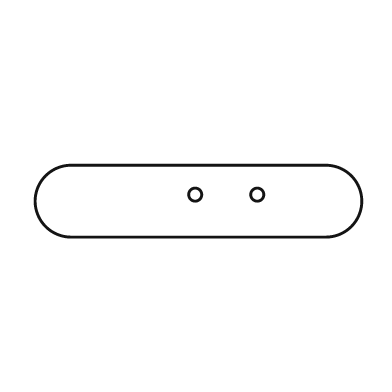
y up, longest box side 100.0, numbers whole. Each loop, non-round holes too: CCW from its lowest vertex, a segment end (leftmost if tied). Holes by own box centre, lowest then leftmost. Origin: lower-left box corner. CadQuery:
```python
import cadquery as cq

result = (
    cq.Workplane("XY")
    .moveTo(11.0, 0.0)
    .lineTo(89.0, 0.0)
    .threePointArc((100.0, 11.0), (89.0, 22.0))
    .lineTo(11.0, 22.0)
    .threePointArc((0.0, 11.0), (11.0, 0.0))
    .close()
    .moveTo(49.0, 13.0)
    .circle(2.0)
    .moveTo(68.0, 13.0)
    .circle(2.0)
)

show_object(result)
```